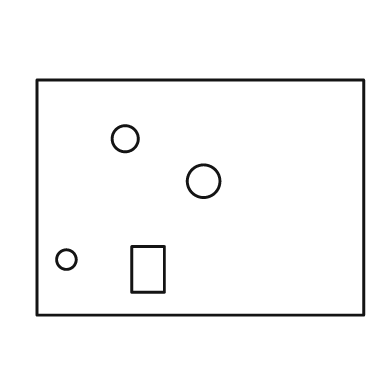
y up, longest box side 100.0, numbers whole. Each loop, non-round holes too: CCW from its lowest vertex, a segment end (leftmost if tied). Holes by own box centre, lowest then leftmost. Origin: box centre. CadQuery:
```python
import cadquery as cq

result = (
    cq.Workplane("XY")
    .moveTo(-50.0, -36.0)
    .lineTo(50.0, -36.0)
    .lineTo(50.0, 36.0)
    .lineTo(-50.0, 36.0)
    .close()
    .moveTo(-21.0, -29.0)
    .lineTo(-11.0, -29.0)
    .lineTo(-11.0, -15.0)
    .lineTo(-21.0, -15.0)
    .close()
    .moveTo(-41.0, -19.0)
    .circle(3.0)
    .moveTo(1.0, 5.0)
    .circle(5.0)
    .moveTo(-23.0, 18.0)
    .circle(4.0)
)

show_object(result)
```